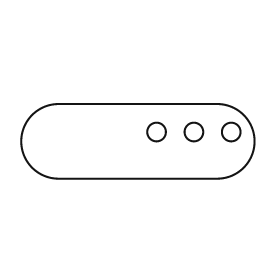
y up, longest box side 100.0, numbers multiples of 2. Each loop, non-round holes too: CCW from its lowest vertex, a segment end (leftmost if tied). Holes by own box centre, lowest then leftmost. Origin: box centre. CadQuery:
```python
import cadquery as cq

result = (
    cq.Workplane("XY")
    .moveTo(-34.0, -16.0)
    .lineTo(34.0, -16.0)
    .threePointArc((50.0, 0.0), (34.0, 16.0))
    .lineTo(-34.0, 16.0)
    .threePointArc((-50.0, 0.0), (-34.0, -16.0))
    .close()
    .moveTo(8.0, 4.0)
    .circle(4.0)
    .moveTo(24.0, 4.0)
    .circle(4.0)
    .moveTo(40.0, 4.0)
    .circle(4.0)
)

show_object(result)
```